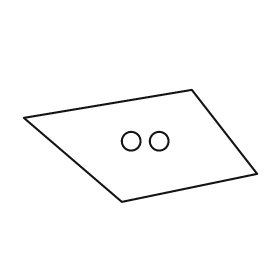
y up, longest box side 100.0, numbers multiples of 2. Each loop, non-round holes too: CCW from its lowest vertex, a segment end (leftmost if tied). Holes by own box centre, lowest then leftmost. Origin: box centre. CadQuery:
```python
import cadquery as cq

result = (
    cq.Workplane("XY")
    .moveTo(-8.0, -24.0)
    .lineTo(50.0, -12.0)
    .lineTo(22.0, 24.0)
    .lineTo(-50.0, 12.0)
    .close()
    .moveTo(-4.0, 2.0)
    .circle(4.0)
    .moveTo(8.0, 2.0)
    .circle(4.0)
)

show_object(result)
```